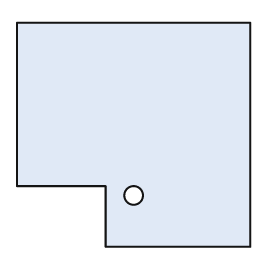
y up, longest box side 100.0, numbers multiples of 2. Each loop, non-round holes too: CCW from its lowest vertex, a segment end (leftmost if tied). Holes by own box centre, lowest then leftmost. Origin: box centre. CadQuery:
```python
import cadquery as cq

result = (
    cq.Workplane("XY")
    .moveTo(-12.0, -48.0)
    .lineTo(50.0, -48.0)
    .lineTo(50.0, 48.0)
    .lineTo(-50.0, 48.0)
    .lineTo(-50.0, -22.0)
    .lineTo(-12.0, -22.0)
    .close()
    .moveTo(0.0, -26.0)
    .circle(4.0)
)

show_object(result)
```